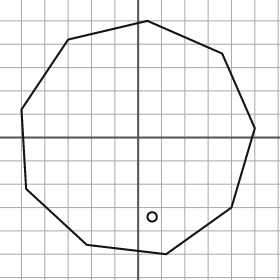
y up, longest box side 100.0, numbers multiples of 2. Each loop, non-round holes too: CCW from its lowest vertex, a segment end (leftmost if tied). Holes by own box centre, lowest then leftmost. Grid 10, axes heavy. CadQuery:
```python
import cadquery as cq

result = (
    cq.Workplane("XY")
    .moveTo(12.0, -50.0)
    .lineTo(40.0, -30.0)
    .lineTo(50.0, 4.0)
    .lineTo(36.0, 36.0)
    .lineTo(4.0, 50.0)
    .lineTo(-30.0, 42.0)
    .lineTo(-50.0, 12.0)
    .lineTo(-48.0, -22.0)
    .lineTo(-22.0, -46.0)
    .close()
    .moveTo(6.0, -34.0)
    .circle(2.0)
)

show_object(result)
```